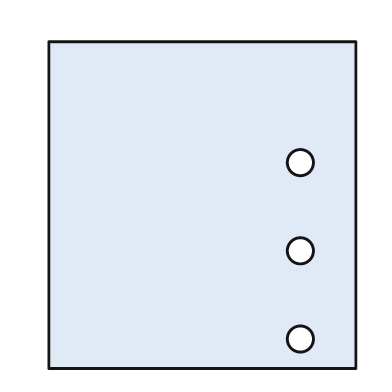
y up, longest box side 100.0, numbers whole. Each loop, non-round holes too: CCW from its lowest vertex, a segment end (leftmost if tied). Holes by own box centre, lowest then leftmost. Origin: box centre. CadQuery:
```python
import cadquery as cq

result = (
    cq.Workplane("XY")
    .moveTo(-47.0, -50.0)
    .lineTo(47.0, -50.0)
    .lineTo(47.0, 50.0)
    .lineTo(-47.0, 50.0)
    .close()
    .moveTo(30.0, -41.0)
    .circle(4.0)
    .moveTo(30.0, -14.0)
    .circle(4.0)
    .moveTo(30.0, 13.0)
    .circle(4.0)
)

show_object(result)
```